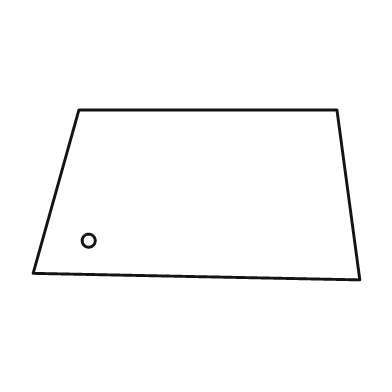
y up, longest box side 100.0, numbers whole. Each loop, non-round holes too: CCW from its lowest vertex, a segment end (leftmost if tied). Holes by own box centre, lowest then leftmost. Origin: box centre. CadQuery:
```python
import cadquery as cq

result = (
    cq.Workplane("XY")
    .moveTo(50.0, -26.0)
    .lineTo(43.0, 26.0)
    .lineTo(-36.0, 26.0)
    .lineTo(-50.0, -24.0)
    .close()
    .moveTo(-33.0, -14.0)
    .circle(2.0)
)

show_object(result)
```